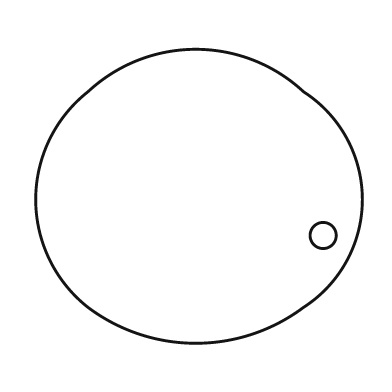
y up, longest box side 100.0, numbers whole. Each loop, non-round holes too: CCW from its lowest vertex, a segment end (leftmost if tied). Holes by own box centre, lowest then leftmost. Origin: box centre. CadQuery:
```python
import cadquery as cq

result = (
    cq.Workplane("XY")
    .moveTo(-34.0, -34.0)
    .threePointArc((-1.0, -45.0), (32.0, -34.0))
    .threePointArc((50.0, -1.0), (32.0, 32.0))
    .threePointArc((-1.0, 45.0), (-34.0, 32.0))
    .threePointArc((-50.0, -1.0), (-34.0, -34.0))
    .close()
    .moveTo(38.0, -12.0)
    .circle(4.0)
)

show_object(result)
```